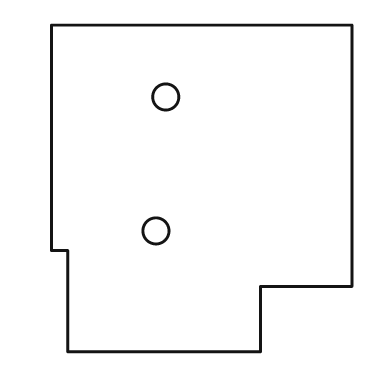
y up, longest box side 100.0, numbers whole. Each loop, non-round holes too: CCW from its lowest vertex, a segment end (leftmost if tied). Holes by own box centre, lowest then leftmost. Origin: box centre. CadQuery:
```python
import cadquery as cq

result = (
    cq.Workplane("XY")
    .moveTo(-41.0, -50.0)
    .lineTo(18.0, -50.0)
    .lineTo(18.0, -30.0)
    .lineTo(46.0, -30.0)
    .lineTo(46.0, 50.0)
    .lineTo(-46.0, 50.0)
    .lineTo(-46.0, -19.0)
    .lineTo(-41.0, -19.0)
    .close()
    .moveTo(-14.0, -13.0)
    .circle(4.0)
    .moveTo(-11.0, 28.0)
    .circle(4.0)
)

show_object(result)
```